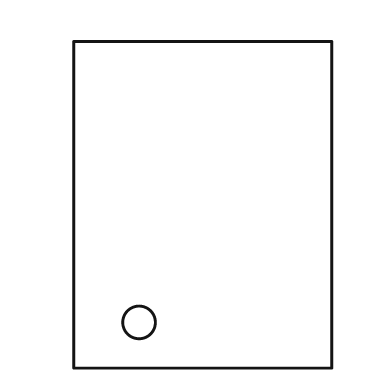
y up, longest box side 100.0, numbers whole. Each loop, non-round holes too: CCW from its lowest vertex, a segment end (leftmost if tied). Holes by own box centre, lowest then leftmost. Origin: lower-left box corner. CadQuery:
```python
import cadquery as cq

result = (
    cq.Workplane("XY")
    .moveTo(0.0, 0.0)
    .lineTo(79.0, 0.0)
    .lineTo(79.0, 100.0)
    .lineTo(0.0, 100.0)
    .close()
    .moveTo(20.0, 14.0)
    .circle(5.0)
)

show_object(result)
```